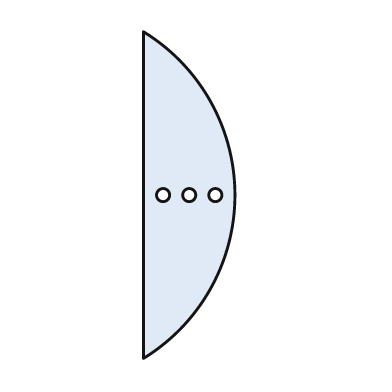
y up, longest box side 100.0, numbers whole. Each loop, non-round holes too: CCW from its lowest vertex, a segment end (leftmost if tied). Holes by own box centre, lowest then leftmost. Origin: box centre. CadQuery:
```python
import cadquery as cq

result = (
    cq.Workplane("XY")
    .moveTo(-14.0, -50.0)
    .threePointArc((14.0, 0.0), (-14.0, 50.0))
    .close()
    .moveTo(-8.0, 0.0)
    .circle(2.0)
    .moveTo(0.0, 0.0)
    .circle(2.0)
    .moveTo(8.0, 0.0)
    .circle(2.0)
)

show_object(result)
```